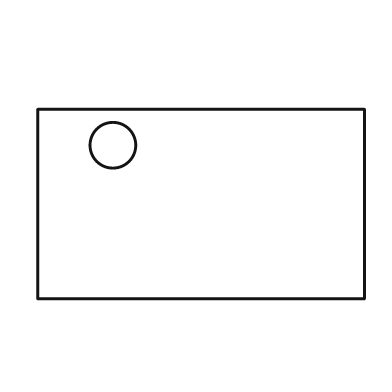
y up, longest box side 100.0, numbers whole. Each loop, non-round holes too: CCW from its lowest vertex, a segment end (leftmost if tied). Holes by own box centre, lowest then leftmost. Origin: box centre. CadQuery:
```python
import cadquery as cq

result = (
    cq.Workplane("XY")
    .moveTo(-50.0, -29.0)
    .lineTo(50.0, -29.0)
    .lineTo(50.0, 29.0)
    .lineTo(-50.0, 29.0)
    .close()
    .moveTo(-27.0, 18.0)
    .circle(7.0)
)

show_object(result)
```